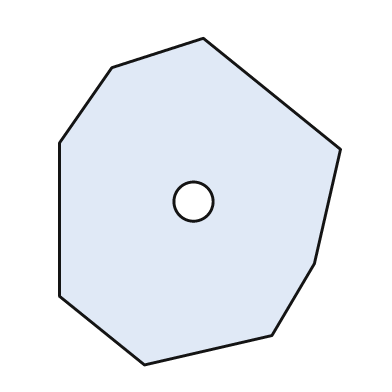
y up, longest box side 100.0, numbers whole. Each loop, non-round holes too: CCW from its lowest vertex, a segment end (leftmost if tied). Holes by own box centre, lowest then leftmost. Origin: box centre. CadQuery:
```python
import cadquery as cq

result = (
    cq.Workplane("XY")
    .moveTo(-17.0, -50.0)
    .lineTo(22.0, -41.0)
    .lineTo(35.0, -19.0)
    .lineTo(43.0, 16.0)
    .lineTo(1.0, 50.0)
    .lineTo(-27.0, 41.0)
    .lineTo(-43.0, 18.0)
    .lineTo(-43.0, -29.0)
    .close()
    .moveTo(-2.0, 0.0)
    .circle(6.0)
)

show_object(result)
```